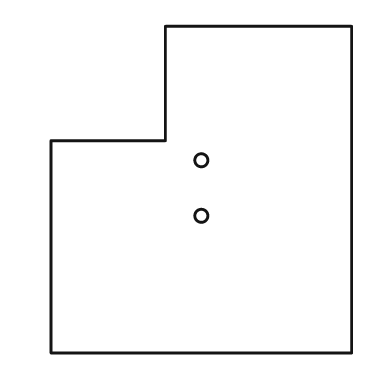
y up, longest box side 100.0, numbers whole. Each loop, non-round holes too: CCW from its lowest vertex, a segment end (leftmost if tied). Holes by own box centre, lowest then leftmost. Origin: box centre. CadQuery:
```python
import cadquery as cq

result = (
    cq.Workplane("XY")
    .moveTo(-46.0, -50.0)
    .lineTo(46.0, -50.0)
    .lineTo(46.0, 50.0)
    .lineTo(-11.0, 50.0)
    .lineTo(-11.0, 15.0)
    .lineTo(-46.0, 15.0)
    .close()
    .moveTo(0.0, -8.0)
    .circle(2.0)
    .moveTo(0.0, 9.0)
    .circle(2.0)
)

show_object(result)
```